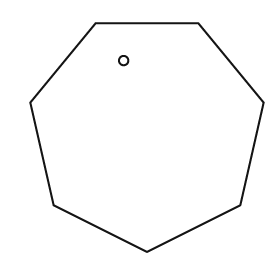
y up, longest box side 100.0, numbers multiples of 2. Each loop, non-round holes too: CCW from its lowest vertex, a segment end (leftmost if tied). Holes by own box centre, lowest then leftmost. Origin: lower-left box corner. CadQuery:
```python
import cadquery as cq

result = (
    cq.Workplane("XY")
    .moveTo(50.0, 0.0)
    .lineTo(90.0, 20.0)
    .lineTo(100.0, 64.0)
    .lineTo(72.0, 98.0)
    .lineTo(28.0, 98.0)
    .lineTo(0.0, 64.0)
    .lineTo(10.0, 20.0)
    .close()
    .moveTo(40.0, 82.0)
    .circle(2.0)
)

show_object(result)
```